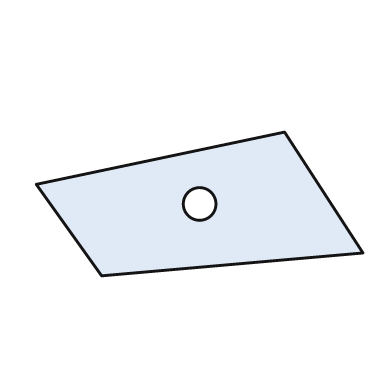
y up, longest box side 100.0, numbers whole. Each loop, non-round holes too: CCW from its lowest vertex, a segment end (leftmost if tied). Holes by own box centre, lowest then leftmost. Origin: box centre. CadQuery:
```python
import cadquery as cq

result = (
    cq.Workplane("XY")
    .moveTo(-30.0, -22.0)
    .lineTo(50.0, -15.0)
    .lineTo(26.0, 22.0)
    .lineTo(-50.0, 6.0)
    .close()
    .moveTo(0.0, 0.0)
    .circle(5.0)
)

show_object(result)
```